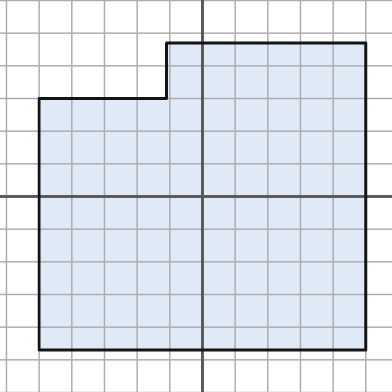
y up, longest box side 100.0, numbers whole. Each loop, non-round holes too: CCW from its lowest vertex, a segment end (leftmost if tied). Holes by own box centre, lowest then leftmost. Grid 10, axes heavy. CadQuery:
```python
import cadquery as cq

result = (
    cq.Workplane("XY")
    .moveTo(-50.0, -47.0)
    .lineTo(50.0, -47.0)
    .lineTo(50.0, 47.0)
    .lineTo(-11.0, 47.0)
    .lineTo(-11.0, 30.0)
    .lineTo(-50.0, 30.0)
    .close()
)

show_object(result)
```